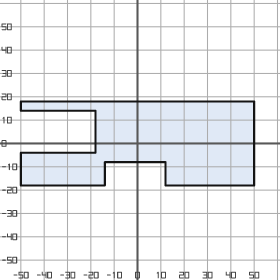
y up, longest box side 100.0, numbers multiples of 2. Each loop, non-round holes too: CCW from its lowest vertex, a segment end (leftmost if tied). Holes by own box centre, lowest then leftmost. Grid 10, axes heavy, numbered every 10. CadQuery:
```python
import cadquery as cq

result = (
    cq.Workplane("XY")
    .moveTo(-50.0, -18.0)
    .lineTo(-14.0, -18.0)
    .lineTo(-14.0, -8.0)
    .lineTo(12.0, -8.0)
    .lineTo(12.0, -18.0)
    .lineTo(50.0, -18.0)
    .lineTo(50.0, 18.0)
    .lineTo(-50.0, 18.0)
    .lineTo(-50.0, 14.0)
    .lineTo(-18.0, 14.0)
    .lineTo(-18.0, -4.0)
    .lineTo(-50.0, -4.0)
    .close()
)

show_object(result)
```